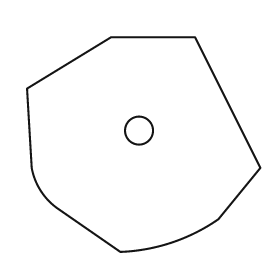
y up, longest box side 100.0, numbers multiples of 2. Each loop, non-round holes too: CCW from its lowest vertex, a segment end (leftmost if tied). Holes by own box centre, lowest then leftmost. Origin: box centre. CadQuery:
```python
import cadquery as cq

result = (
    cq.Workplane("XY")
    .moveTo(-10.0, -46.0)
    .threePointArc((12.0, -42.0), (32.0, -32.0))
    .lineTo(50.0, -10.0)
    .lineTo(22.0, 46.0)
    .lineTo(-14.0, 46.0)
    .lineTo(-50.0, 24.0)
    .lineTo(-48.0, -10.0)
    .threePointArc((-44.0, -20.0), (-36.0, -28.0))
    .close()
    .moveTo(-2.0, 6.0)
    .circle(6.0)
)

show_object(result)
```